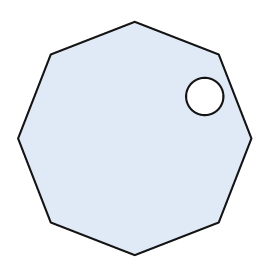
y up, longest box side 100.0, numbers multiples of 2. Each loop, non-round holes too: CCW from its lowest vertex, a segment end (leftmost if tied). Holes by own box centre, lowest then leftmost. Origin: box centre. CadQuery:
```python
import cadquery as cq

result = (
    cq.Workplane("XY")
    .moveTo(0.0, -50.0)
    .lineTo(36.0, -36.0)
    .lineTo(50.0, 0.0)
    .lineTo(36.0, 36.0)
    .lineTo(0.0, 50.0)
    .lineTo(-36.0, 36.0)
    .lineTo(-50.0, 0.0)
    .lineTo(-36.0, -36.0)
    .close()
    .moveTo(30.0, 18.0)
    .circle(8.0)
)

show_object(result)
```